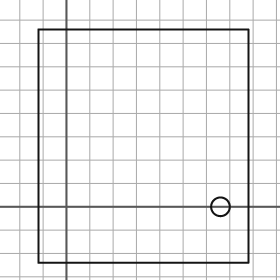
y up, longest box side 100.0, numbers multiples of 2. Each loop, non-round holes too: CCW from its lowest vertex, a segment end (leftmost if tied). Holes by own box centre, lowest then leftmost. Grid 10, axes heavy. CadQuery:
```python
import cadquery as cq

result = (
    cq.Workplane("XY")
    .moveTo(-12.0, -24.0)
    .lineTo(78.0, -24.0)
    .lineTo(78.0, 76.0)
    .lineTo(-12.0, 76.0)
    .close()
    .moveTo(66.0, 0.0)
    .circle(4.0)
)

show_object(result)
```